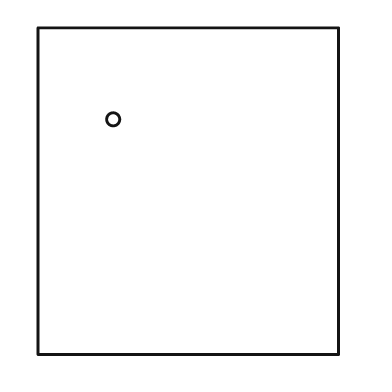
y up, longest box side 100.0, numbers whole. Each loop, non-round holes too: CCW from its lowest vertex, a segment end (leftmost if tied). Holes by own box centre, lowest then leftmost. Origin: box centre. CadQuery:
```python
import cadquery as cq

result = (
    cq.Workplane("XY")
    .moveTo(-46.0, -50.0)
    .lineTo(46.0, -50.0)
    .lineTo(46.0, 50.0)
    .lineTo(-46.0, 50.0)
    .close()
    .moveTo(-23.0, 22.0)
    .circle(2.0)
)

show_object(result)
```